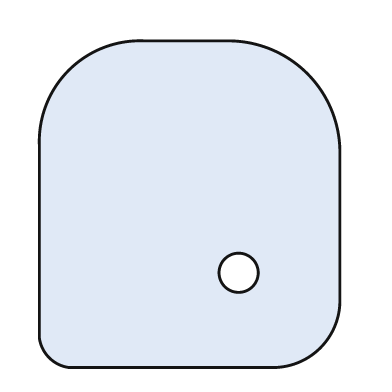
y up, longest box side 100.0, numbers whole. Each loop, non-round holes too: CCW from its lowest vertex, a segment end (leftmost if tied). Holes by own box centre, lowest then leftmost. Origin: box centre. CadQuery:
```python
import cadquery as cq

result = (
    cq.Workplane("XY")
    .moveTo(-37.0, -50.0)
    .lineTo(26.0, -50.0)
    .threePointArc((40.0, -44.0), (46.0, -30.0))
    .lineTo(46.0, 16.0)
    .threePointArc((36.0, 40.0), (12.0, 50.0))
    .lineTo(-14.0, 50.0)
    .threePointArc((-37.0, 41.0), (-46.0, 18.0))
    .lineTo(-46.0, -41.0)
    .threePointArc((-43.0, -47.0), (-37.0, -50.0))
    .close()
    .moveTo(15.0, -21.0)
    .circle(6.0)
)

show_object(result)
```